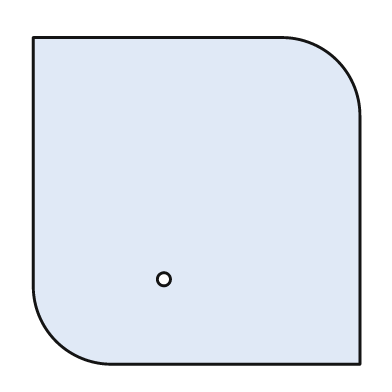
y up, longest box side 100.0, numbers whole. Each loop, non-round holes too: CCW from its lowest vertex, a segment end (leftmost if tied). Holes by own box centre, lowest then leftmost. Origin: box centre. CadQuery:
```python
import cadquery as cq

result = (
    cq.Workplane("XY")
    .moveTo(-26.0, -50.0)
    .lineTo(50.0, -50.0)
    .lineTo(50.0, 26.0)
    .threePointArc((43.0, 43.0), (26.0, 50.0))
    .lineTo(-50.0, 50.0)
    .lineTo(-50.0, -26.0)
    .threePointArc((-43.0, -43.0), (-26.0, -50.0))
    .close()
    .moveTo(-10.0, -24.0)
    .circle(2.0)
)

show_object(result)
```